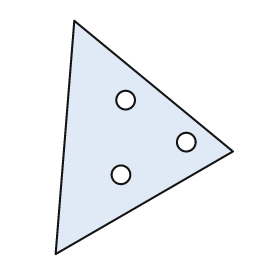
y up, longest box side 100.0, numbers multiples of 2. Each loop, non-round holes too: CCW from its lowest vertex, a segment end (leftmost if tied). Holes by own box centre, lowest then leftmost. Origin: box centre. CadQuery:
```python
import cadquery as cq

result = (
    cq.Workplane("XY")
    .moveTo(-38.0, -50.0)
    .lineTo(38.0, -6.0)
    .lineTo(-30.0, 50.0)
    .close()
    .moveTo(-10.0, -16.0)
    .circle(4.0)
    .moveTo(18.0, -2.0)
    .circle(4.0)
    .moveTo(-8.0, 16.0)
    .circle(4.0)
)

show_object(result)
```